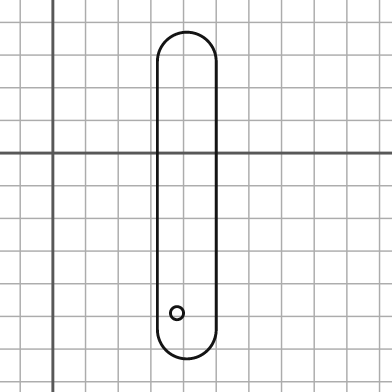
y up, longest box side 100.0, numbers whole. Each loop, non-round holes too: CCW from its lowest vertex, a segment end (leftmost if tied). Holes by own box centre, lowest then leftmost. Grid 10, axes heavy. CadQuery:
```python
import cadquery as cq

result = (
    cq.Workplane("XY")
    .moveTo(32.0, -54.0)
    .threePointArc((41.0, -63.0), (50.0, -54.0))
    .lineTo(50.0, 28.0)
    .threePointArc((41.0, 37.0), (32.0, 28.0))
    .close()
    .moveTo(38.0, -49.0)
    .circle(2.0)
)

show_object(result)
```